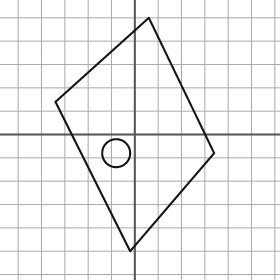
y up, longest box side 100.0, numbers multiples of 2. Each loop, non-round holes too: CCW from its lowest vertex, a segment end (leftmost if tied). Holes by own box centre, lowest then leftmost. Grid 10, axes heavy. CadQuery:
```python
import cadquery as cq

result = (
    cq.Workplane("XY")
    .moveTo(-2.0, -50.0)
    .lineTo(34.0, -8.0)
    .lineTo(6.0, 50.0)
    .lineTo(-34.0, 14.0)
    .close()
    .moveTo(-8.0, -8.0)
    .circle(6.0)
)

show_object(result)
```